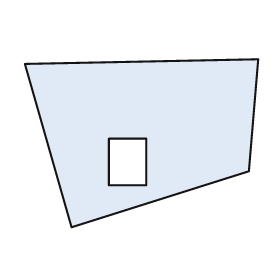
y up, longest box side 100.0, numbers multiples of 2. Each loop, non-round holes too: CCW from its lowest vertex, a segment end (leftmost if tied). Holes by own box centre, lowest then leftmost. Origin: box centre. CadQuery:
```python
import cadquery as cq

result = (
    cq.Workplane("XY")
    .moveTo(-30.0, -36.0)
    .lineTo(46.0, -12.0)
    .lineTo(50.0, 36.0)
    .lineTo(-50.0, 34.0)
    .close()
    .moveTo(-14.0, -18.0)
    .lineTo(2.0, -18.0)
    .lineTo(2.0, 2.0)
    .lineTo(-14.0, 2.0)
    .close()
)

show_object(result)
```